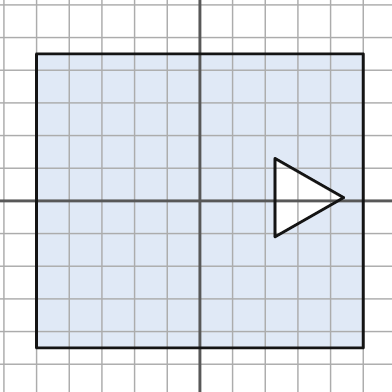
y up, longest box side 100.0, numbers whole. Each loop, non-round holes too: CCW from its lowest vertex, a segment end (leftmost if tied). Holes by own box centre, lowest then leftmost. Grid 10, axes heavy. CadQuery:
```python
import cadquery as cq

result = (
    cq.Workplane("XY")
    .moveTo(-50.0, -45.0)
    .lineTo(50.0, -45.0)
    .lineTo(50.0, 45.0)
    .lineTo(-50.0, 45.0)
    .close()
    .moveTo(23.0, -11.0)
    .lineTo(44.0, 1.0)
    .lineTo(23.0, 13.0)
    .close()
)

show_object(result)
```